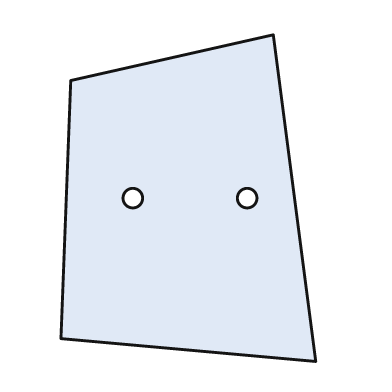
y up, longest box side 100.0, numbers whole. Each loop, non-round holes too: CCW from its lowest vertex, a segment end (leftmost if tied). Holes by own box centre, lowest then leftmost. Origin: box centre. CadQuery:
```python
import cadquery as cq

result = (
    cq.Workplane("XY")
    .moveTo(39.0, -50.0)
    .lineTo(26.0, 50.0)
    .lineTo(-36.0, 36.0)
    .lineTo(-39.0, -43.0)
    .close()
    .moveTo(-17.0, 0.0)
    .circle(3.0)
    .moveTo(18.0, 0.0)
    .circle(3.0)
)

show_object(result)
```